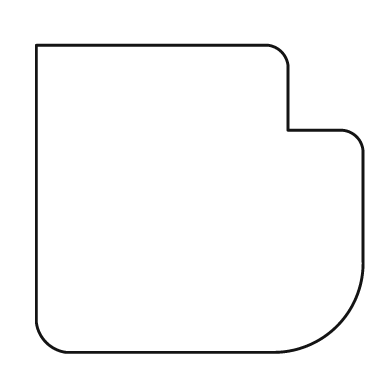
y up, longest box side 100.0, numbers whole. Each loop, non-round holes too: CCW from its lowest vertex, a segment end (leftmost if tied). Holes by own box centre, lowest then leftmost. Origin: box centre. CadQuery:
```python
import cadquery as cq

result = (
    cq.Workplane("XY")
    .moveTo(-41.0, -47.0)
    .lineTo(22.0, -47.0)
    .threePointArc((42.0, -39.0), (50.0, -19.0))
    .lineTo(50.0, 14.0)
    .threePointArc((48.0, 19.0), (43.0, 21.0))
    .lineTo(27.0, 21.0)
    .lineTo(27.0, 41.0)
    .threePointArc((25.0, 45.0), (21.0, 47.0))
    .lineTo(-50.0, 47.0)
    .lineTo(-50.0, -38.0)
    .threePointArc((-47.0, -44.0), (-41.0, -47.0))
    .close()
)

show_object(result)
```